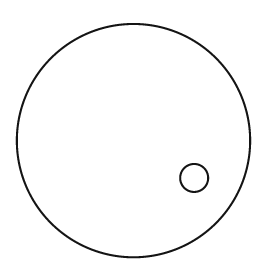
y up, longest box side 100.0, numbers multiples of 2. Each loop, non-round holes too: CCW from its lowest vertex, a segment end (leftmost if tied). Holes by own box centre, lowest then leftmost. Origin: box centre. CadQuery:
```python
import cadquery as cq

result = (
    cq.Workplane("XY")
    .moveTo(0.0, 0.0)
    .circle(50.0)
    .moveTo(26.0, -16.0)
    .circle(6.0)
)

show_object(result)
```